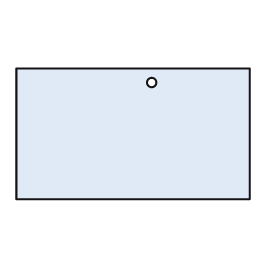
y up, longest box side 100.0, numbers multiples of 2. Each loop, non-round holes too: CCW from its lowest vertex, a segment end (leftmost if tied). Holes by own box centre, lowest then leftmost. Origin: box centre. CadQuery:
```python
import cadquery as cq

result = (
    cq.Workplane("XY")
    .moveTo(-50.0, -28.0)
    .lineTo(50.0, -28.0)
    .lineTo(50.0, 28.0)
    .lineTo(-50.0, 28.0)
    .close()
    .moveTo(8.0, 22.0)
    .circle(2.0)
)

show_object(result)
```